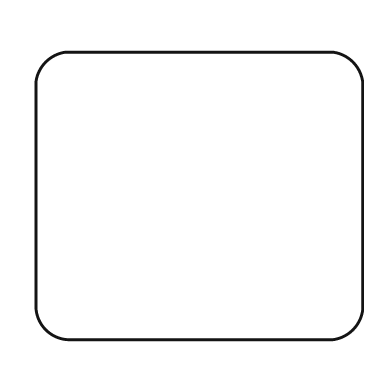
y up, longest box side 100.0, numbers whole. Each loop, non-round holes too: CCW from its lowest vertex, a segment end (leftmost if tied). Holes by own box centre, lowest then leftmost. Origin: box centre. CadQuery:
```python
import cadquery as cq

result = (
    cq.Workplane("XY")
    .moveTo(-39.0, -44.0)
    .lineTo(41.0, -44.0)
    .threePointArc((47.0, -41.0), (50.0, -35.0))
    .lineTo(50.0, 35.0)
    .threePointArc((47.0, 41.0), (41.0, 44.0))
    .lineTo(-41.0, 44.0)
    .threePointArc((-47.0, 41.0), (-50.0, 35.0))
    .lineTo(-50.0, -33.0)
    .threePointArc((-47.0, -41.0), (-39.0, -44.0))
    .close()
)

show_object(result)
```